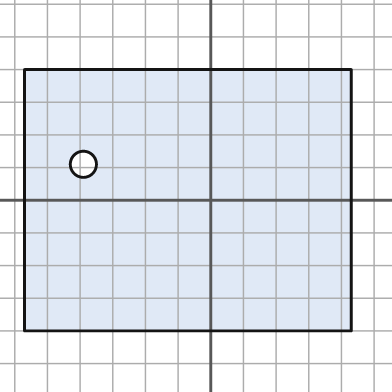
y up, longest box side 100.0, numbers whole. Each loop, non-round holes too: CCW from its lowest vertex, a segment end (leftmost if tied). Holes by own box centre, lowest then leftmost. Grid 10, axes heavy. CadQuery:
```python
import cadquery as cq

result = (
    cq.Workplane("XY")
    .moveTo(-57.0, -40.0)
    .lineTo(43.0, -40.0)
    .lineTo(43.0, 40.0)
    .lineTo(-57.0, 40.0)
    .close()
    .moveTo(-39.0, 11.0)
    .circle(4.0)
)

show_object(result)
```